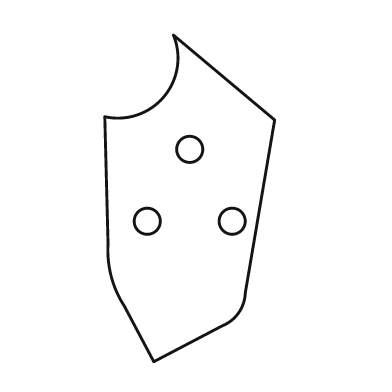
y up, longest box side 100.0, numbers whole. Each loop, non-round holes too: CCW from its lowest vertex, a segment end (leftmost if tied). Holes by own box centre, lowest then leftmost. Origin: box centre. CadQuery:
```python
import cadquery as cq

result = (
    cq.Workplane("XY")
    .moveTo(-11.0, -50.0)
    .lineTo(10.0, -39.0)
    .threePointArc((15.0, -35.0), (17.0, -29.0))
    .lineTo(26.0, 24.0)
    .lineTo(-5.0, 50.0)
    .threePointArc((-8.0, 31.0), (-26.0, 25.0))
    .lineTo(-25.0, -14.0)
    .threePointArc((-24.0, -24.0), (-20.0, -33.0))
    .close()
    .moveTo(-13.0, -7.0)
    .circle(4.0)
    .moveTo(13.0, -7.0)
    .circle(4.0)
    .moveTo(0.0, 15.0)
    .circle(4.0)
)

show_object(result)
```